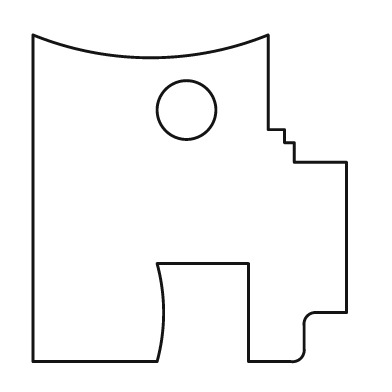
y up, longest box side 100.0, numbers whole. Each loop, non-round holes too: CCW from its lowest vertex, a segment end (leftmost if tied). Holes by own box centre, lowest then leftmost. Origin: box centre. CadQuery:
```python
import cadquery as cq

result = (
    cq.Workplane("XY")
    .moveTo(-48.0, -50.0)
    .lineTo(-10.0, -50.0)
    .threePointArc((-8.0, -35.0), (-10.0, -20.0))
    .lineTo(18.0, -20.0)
    .lineTo(18.0, -50.0)
    .lineTo(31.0, -50.0)
    .threePointArc((34.0, -49.0), (35.0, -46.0))
    .lineTo(35.0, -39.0)
    .threePointArc((36.0, -36.0), (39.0, -35.0))
    .lineTo(48.0, -35.0)
    .lineTo(48.0, 11.0)
    .lineTo(32.0, 11.0)
    .lineTo(32.0, 17.0)
    .lineTo(29.0, 17.0)
    .lineTo(29.0, 21.0)
    .lineTo(24.0, 21.0)
    .lineTo(24.0, 50.0)
    .threePointArc((-12.0, 43.0), (-48.0, 50.0))
    .close()
    .moveTo(-1.0, 27.0)
    .circle(9.0)
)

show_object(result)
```